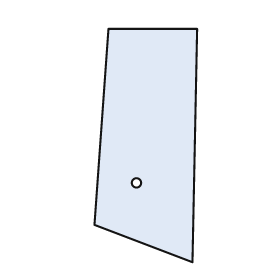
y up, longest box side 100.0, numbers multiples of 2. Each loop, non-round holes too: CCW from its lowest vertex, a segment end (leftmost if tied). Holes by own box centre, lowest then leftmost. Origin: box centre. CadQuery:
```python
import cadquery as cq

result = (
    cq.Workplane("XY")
    .moveTo(20.0, -50.0)
    .lineTo(22.0, 50.0)
    .lineTo(-16.0, 50.0)
    .lineTo(-22.0, -34.0)
    .close()
    .moveTo(-4.0, -16.0)
    .circle(2.0)
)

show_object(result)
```